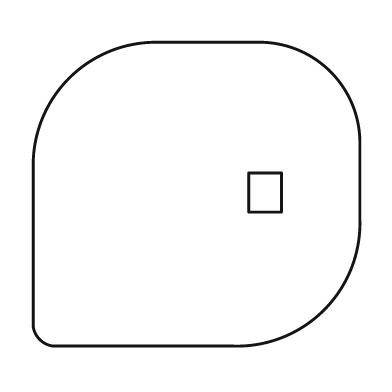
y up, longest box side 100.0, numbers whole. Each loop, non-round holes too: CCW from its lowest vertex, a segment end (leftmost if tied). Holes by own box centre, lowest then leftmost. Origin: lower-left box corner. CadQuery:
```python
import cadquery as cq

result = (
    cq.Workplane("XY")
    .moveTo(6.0, 0.0)
    .lineTo(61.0, 0.0)
    .threePointArc((89.0, 11.0), (100.0, 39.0))
    .lineTo(100.0, 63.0)
    .threePointArc((91.0, 84.0), (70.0, 93.0))
    .lineTo(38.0, 93.0)
    .threePointArc((11.0, 82.0), (0.0, 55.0))
    .lineTo(0.0, 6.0)
    .threePointArc((2.0, 2.0), (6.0, 0.0))
    .close()
    .moveTo(66.0, 41.0)
    .lineTo(76.0, 41.0)
    .lineTo(76.0, 53.0)
    .lineTo(66.0, 53.0)
    .close()
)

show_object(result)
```